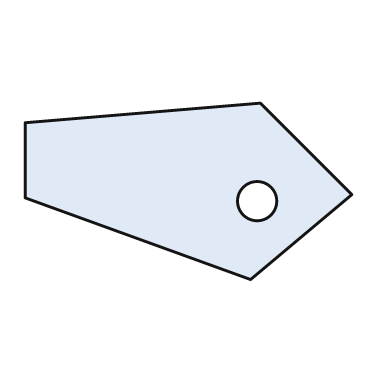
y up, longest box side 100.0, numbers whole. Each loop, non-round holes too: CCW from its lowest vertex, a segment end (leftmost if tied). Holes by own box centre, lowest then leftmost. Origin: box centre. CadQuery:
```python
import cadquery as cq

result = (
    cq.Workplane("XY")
    .moveTo(19.0, -27.0)
    .lineTo(50.0, -1.0)
    .lineTo(22.0, 27.0)
    .lineTo(-50.0, 21.0)
    .lineTo(-50.0, -2.0)
    .close()
    .moveTo(21.0, -3.0)
    .circle(6.0)
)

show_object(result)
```